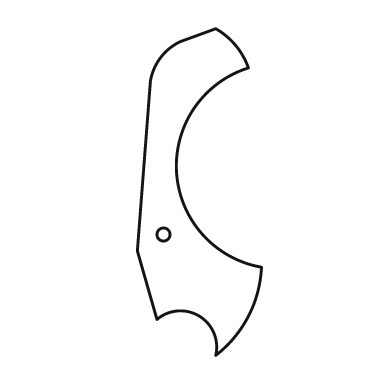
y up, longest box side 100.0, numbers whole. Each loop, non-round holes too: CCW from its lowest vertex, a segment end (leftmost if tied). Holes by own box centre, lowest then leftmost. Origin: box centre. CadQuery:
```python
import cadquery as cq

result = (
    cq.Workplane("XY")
    .moveTo(5.0, -50.0)
    .threePointArc((15.0, -38.0), (19.0, -23.0))
    .threePointArc((-7.0, 6.0), (15.0, 38.0))
    .threePointArc((11.0, 45.0), (5.0, 50.0))
    .lineTo(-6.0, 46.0)
    .threePointArc((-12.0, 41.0), (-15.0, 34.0))
    .lineTo(-19.0, -18.0)
    .lineTo(-13.0, -39.0)
    .threePointArc((0.0, -38.0), (5.0, -50.0))
    .close()
    .moveTo(-11.0, -13.0)
    .circle(2.0)
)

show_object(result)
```